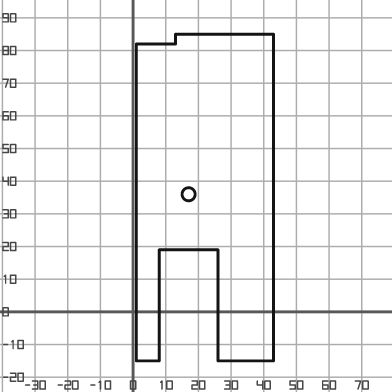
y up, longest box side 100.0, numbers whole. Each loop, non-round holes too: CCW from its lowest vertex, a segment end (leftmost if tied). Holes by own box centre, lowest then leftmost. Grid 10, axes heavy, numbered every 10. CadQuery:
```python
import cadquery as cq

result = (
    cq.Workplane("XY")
    .moveTo(1.0, -15.0)
    .lineTo(8.0, -15.0)
    .lineTo(8.0, 19.0)
    .lineTo(26.0, 19.0)
    .lineTo(26.0, -15.0)
    .lineTo(43.0, -15.0)
    .lineTo(43.0, 85.0)
    .lineTo(13.0, 85.0)
    .lineTo(13.0, 82.0)
    .lineTo(1.0, 82.0)
    .close()
    .moveTo(17.0, 36.0)
    .circle(2.0)
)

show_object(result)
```